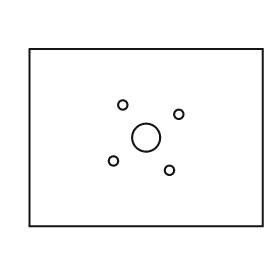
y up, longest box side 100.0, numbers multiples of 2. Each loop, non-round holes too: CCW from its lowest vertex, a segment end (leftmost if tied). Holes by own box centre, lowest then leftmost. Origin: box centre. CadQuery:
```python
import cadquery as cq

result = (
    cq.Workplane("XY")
    .moveTo(-50.0, -38.0)
    .lineTo(50.0, -38.0)
    .lineTo(50.0, 38.0)
    .lineTo(-50.0, 38.0)
    .close()
    .moveTo(10.0, -14.0)
    .circle(2.0)
    .moveTo(-14.0, -10.0)
    .circle(2.0)
    .moveTo(0.0, 0.0)
    .circle(6.0)
    .moveTo(14.0, 10.0)
    .circle(2.0)
    .moveTo(-10.0, 14.0)
    .circle(2.0)
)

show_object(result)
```